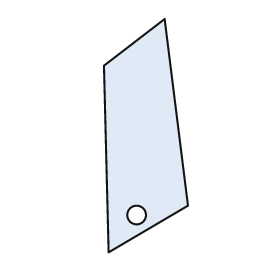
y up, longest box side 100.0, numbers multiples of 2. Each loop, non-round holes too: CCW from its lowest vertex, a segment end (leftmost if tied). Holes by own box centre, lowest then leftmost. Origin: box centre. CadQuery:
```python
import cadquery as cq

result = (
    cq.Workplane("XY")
    .moveTo(-16.0, -50.0)
    .lineTo(18.0, -30.0)
    .lineTo(8.0, 50.0)
    .lineTo(-18.0, 30.0)
    .close()
    .moveTo(-4.0, -34.0)
    .circle(4.0)
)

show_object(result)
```